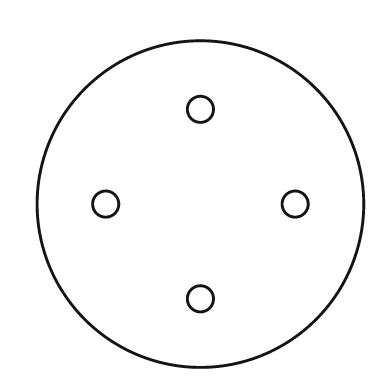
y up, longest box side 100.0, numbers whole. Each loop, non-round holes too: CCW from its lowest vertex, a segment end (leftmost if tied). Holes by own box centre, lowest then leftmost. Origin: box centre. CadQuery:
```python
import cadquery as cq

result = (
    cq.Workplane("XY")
    .moveTo(0.0, 0.0)
    .circle(50.0)
    .moveTo(0.0, -29.0)
    .circle(4.0)
    .moveTo(-29.0, 0.0)
    .circle(4.0)
    .moveTo(29.0, 0.0)
    .circle(4.0)
    .moveTo(0.0, 29.0)
    .circle(4.0)
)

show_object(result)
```